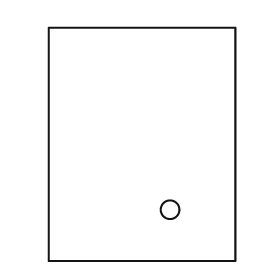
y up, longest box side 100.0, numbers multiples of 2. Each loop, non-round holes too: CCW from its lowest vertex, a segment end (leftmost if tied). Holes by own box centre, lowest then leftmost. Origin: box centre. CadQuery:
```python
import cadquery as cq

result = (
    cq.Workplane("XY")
    .moveTo(-40.0, -50.0)
    .lineTo(40.0, -50.0)
    .lineTo(40.0, 50.0)
    .lineTo(-40.0, 50.0)
    .close()
    .moveTo(12.0, -28.0)
    .circle(4.0)
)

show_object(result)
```